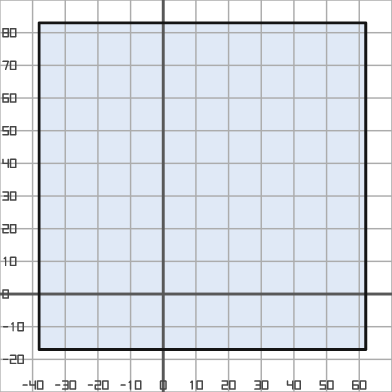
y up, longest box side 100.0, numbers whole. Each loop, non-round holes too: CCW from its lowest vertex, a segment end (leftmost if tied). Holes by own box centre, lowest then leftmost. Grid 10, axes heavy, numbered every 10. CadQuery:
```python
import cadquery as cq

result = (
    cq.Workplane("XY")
    .moveTo(-38.0, -17.0)
    .lineTo(62.0, -17.0)
    .lineTo(62.0, 83.0)
    .lineTo(-38.0, 83.0)
    .close()
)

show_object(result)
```